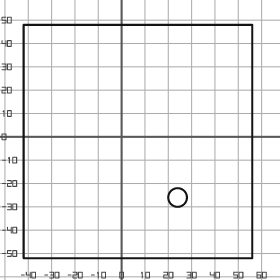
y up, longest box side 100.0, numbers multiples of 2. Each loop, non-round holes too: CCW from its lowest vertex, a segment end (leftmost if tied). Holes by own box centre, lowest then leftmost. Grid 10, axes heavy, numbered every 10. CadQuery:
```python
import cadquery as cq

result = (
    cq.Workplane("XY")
    .moveTo(-42.0, -52.0)
    .lineTo(56.0, -52.0)
    .lineTo(56.0, 48.0)
    .lineTo(-42.0, 48.0)
    .close()
    .moveTo(24.0, -26.0)
    .circle(4.0)
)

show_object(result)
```